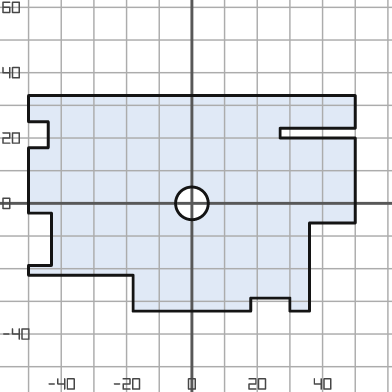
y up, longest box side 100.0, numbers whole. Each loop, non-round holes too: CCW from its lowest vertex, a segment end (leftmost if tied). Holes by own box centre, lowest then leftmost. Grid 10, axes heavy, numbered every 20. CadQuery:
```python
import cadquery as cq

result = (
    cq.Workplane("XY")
    .moveTo(-18.0, -33.0)
    .lineTo(18.0, -33.0)
    .lineTo(18.0, -29.0)
    .lineTo(30.0, -29.0)
    .lineTo(30.0, -33.0)
    .lineTo(36.0, -33.0)
    .lineTo(36.0, -6.0)
    .lineTo(50.0, -6.0)
    .lineTo(50.0, 20.0)
    .lineTo(27.0, 20.0)
    .lineTo(27.0, 23.0)
    .lineTo(50.0, 23.0)
    .lineTo(50.0, 33.0)
    .lineTo(-50.0, 33.0)
    .lineTo(-50.0, 25.0)
    .lineTo(-44.0, 25.0)
    .lineTo(-44.0, 17.0)
    .lineTo(-50.0, 17.0)
    .lineTo(-50.0, -3.0)
    .lineTo(-43.0, -3.0)
    .lineTo(-43.0, -19.0)
    .lineTo(-50.0, -19.0)
    .lineTo(-50.0, -22.0)
    .lineTo(-18.0, -22.0)
    .close()
    .moveTo(0.0, 0.0)
    .circle(5.0)
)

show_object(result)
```